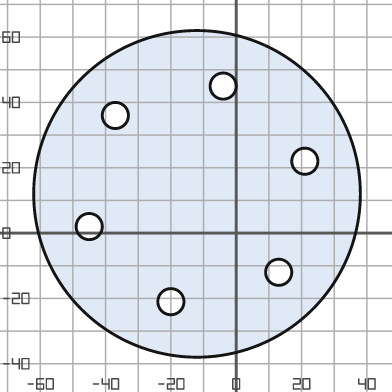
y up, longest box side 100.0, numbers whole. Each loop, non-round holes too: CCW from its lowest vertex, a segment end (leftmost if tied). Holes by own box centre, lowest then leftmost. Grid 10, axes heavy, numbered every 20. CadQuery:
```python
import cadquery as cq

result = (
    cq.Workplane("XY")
    .moveTo(-12.0, 12.0)
    .circle(50.0)
    .moveTo(-20.0, -21.0)
    .circle(4.0)
    .moveTo(13.0, -12.0)
    .circle(4.0)
    .moveTo(-45.0, 2.0)
    .circle(4.0)
    .moveTo(21.0, 22.0)
    .circle(4.0)
    .moveTo(-37.0, 36.0)
    .circle(4.0)
    .moveTo(-4.0, 45.0)
    .circle(4.0)
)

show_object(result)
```